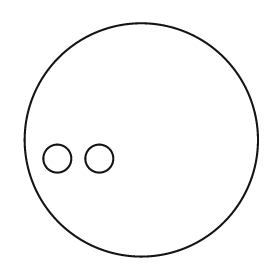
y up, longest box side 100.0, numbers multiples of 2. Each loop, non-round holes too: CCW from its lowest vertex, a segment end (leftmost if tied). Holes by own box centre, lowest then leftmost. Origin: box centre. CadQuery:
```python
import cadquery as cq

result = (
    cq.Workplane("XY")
    .moveTo(0.0, 0.0)
    .circle(50.0)
    .moveTo(-36.0, -8.0)
    .circle(6.0)
    .moveTo(-18.0, -8.0)
    .circle(6.0)
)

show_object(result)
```